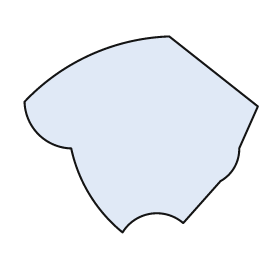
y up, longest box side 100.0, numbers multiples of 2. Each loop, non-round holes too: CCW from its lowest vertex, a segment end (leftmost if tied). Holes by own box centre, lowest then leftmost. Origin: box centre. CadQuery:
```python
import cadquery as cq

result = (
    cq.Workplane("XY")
    .moveTo(-8.0, -42.0)
    .threePointArc((4.0, -34.0), (18.0, -38.0))
    .lineTo(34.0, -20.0)
    .threePointArc((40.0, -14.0), (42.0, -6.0))
    .lineTo(50.0, 12.0)
    .lineTo(12.0, 42.0)
    .threePointArc((-22.0, 34.0), (-50.0, 14.0))
    .threePointArc((-44.0, 0.0), (-30.0, -6.0))
    .threePointArc((-22.0, -26.0), (-8.0, -42.0))
    .close()
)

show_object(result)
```